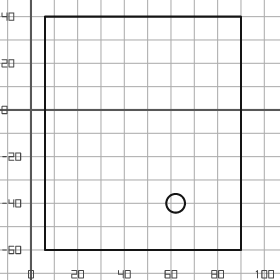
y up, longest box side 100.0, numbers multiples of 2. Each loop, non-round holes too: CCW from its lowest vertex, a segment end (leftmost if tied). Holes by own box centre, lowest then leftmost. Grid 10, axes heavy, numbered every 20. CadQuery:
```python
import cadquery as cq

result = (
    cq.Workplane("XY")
    .moveTo(6.0, -60.0)
    .lineTo(90.0, -60.0)
    .lineTo(90.0, 40.0)
    .lineTo(6.0, 40.0)
    .close()
    .moveTo(62.0, -40.0)
    .circle(4.0)
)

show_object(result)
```